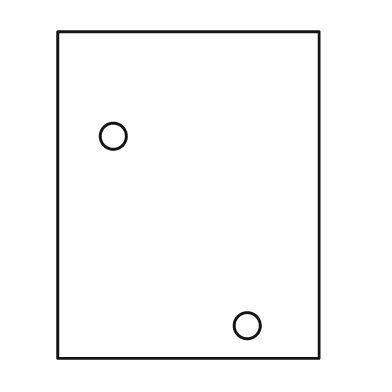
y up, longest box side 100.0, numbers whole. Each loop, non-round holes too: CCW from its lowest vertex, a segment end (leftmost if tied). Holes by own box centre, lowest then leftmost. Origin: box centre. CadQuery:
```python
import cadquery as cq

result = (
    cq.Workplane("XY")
    .moveTo(-40.0, -50.0)
    .lineTo(40.0, -50.0)
    .lineTo(40.0, 50.0)
    .lineTo(-40.0, 50.0)
    .close()
    .moveTo(18.0, -40.0)
    .circle(4.0)
    .moveTo(-23.0, 18.0)
    .circle(4.0)
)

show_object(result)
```